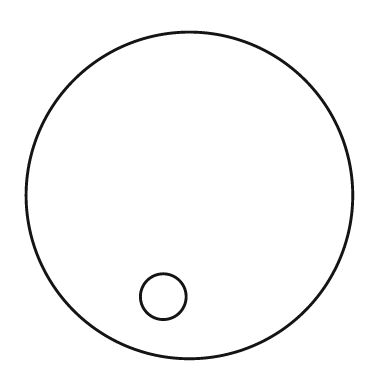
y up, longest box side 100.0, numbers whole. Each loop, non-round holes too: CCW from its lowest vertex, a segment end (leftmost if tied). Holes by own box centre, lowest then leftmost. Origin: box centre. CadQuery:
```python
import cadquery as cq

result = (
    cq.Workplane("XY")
    .moveTo(0.0, 0.0)
    .circle(50.0)
    .moveTo(-8.0, -31.0)
    .circle(7.0)
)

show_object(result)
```